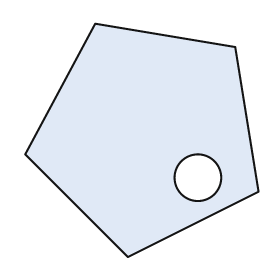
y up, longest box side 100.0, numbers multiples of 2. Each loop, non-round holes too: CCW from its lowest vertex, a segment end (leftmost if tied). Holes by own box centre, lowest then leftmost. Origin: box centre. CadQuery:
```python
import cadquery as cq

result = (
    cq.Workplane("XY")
    .moveTo(-6.0, -50.0)
    .lineTo(50.0, -22.0)
    .lineTo(40.0, 40.0)
    .lineTo(-20.0, 50.0)
    .lineTo(-50.0, -6.0)
    .close()
    .moveTo(24.0, -16.0)
    .circle(10.0)
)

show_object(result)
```